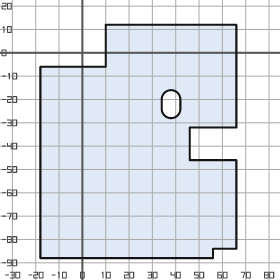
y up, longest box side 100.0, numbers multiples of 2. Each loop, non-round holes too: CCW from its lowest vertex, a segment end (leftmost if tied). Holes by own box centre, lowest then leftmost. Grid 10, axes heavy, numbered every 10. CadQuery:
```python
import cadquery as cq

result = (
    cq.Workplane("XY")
    .moveTo(-18.0, -88.0)
    .lineTo(56.0, -88.0)
    .lineTo(56.0, -84.0)
    .lineTo(66.0, -84.0)
    .lineTo(66.0, -46.0)
    .lineTo(46.0, -46.0)
    .lineTo(46.0, -32.0)
    .lineTo(66.0, -32.0)
    .lineTo(66.0, 12.0)
    .lineTo(10.0, 12.0)
    .lineTo(10.0, -6.0)
    .lineTo(-18.0, -6.0)
    .close()
    .moveTo(34.0, -24.0)
    .threePointArc((38.0, -28.0), (42.0, -24.0))
    .lineTo(42.0, -20.0)
    .threePointArc((38.0, -16.0), (34.0, -20.0))
    .close()
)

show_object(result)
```